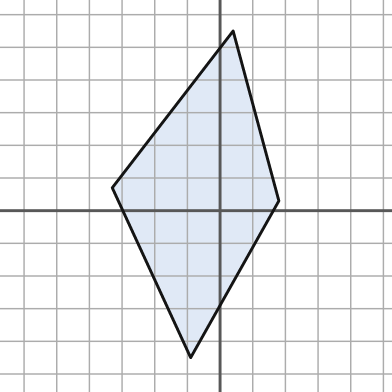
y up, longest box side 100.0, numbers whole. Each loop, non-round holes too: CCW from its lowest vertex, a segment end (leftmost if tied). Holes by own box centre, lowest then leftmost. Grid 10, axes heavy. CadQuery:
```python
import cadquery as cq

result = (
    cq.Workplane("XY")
    .moveTo(-9.0, -45.0)
    .lineTo(18.0, 3.0)
    .lineTo(4.0, 55.0)
    .lineTo(-33.0, 7.0)
    .close()
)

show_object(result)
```